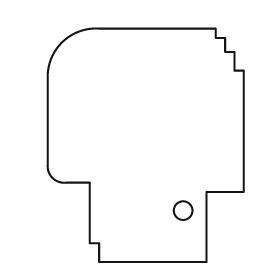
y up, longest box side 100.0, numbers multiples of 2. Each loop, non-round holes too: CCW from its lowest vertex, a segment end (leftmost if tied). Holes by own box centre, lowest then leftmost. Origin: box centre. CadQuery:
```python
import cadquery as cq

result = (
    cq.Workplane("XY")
    .moveTo(-20.0, -50.0)
    .lineTo(26.0, -50.0)
    .lineTo(26.0, -20.0)
    .lineTo(42.0, -20.0)
    .lineTo(42.0, 32.0)
    .lineTo(38.0, 32.0)
    .lineTo(38.0, 40.0)
    .lineTo(34.0, 40.0)
    .lineTo(34.0, 46.0)
    .lineTo(30.0, 46.0)
    .lineTo(30.0, 50.0)
    .lineTo(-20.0, 50.0)
    .threePointArc((-36.0, 44.0), (-42.0, 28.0))
    .lineTo(-42.0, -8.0)
    .threePointArc((-40.0, -14.0), (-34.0, -16.0))
    .lineTo(-24.0, -16.0)
    .lineTo(-24.0, -42.0)
    .lineTo(-20.0, -42.0)
    .close()
    .moveTo(16.0, -28.0)
    .circle(4.0)
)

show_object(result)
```